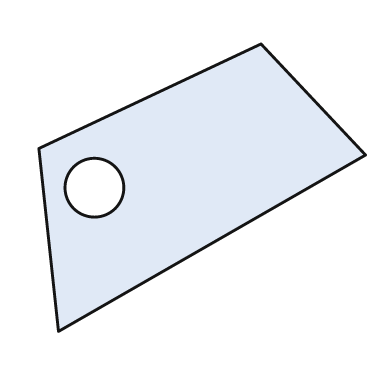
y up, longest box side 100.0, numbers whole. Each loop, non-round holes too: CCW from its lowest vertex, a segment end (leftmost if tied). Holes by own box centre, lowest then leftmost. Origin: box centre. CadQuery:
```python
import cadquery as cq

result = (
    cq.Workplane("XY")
    .moveTo(-44.0, -44.0)
    .lineTo(50.0, 10.0)
    .lineTo(18.0, 44.0)
    .lineTo(-50.0, 12.0)
    .close()
    .moveTo(-33.0, 0.0)
    .circle(9.0)
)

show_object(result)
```